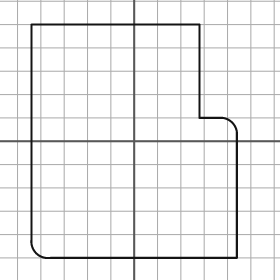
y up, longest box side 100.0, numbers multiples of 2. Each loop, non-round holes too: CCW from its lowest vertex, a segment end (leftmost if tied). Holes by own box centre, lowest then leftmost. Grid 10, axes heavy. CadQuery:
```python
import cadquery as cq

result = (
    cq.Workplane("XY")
    .moveTo(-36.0, -50.0)
    .lineTo(44.0, -50.0)
    .lineTo(44.0, 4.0)
    .threePointArc((42.0, 8.0), (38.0, 10.0))
    .lineTo(28.0, 10.0)
    .lineTo(28.0, 50.0)
    .lineTo(-44.0, 50.0)
    .lineTo(-44.0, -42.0)
    .threePointArc((-42.0, -48.0), (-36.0, -50.0))
    .close()
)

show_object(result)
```